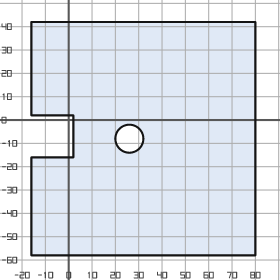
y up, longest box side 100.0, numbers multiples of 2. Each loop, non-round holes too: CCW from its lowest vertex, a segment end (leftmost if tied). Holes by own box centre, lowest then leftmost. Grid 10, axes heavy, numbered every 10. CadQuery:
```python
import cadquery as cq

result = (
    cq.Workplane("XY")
    .moveTo(-16.0, -58.0)
    .lineTo(80.0, -58.0)
    .lineTo(80.0, 42.0)
    .lineTo(-16.0, 42.0)
    .lineTo(-16.0, 2.0)
    .lineTo(2.0, 2.0)
    .lineTo(2.0, -16.0)
    .lineTo(-16.0, -16.0)
    .close()
    .moveTo(26.0, -8.0)
    .circle(6.0)
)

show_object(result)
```